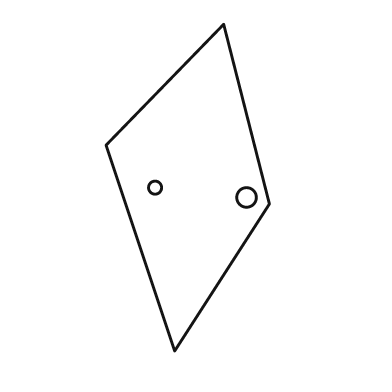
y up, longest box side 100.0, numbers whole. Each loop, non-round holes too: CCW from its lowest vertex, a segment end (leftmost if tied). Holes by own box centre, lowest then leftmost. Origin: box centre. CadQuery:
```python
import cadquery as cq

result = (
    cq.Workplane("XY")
    .moveTo(-4.0, -50.0)
    .lineTo(25.0, -5.0)
    .lineTo(11.0, 50.0)
    .lineTo(-25.0, 13.0)
    .close()
    .moveTo(18.0, -3.0)
    .circle(3.0)
    .moveTo(-10.0, 0.0)
    .circle(2.0)
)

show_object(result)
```